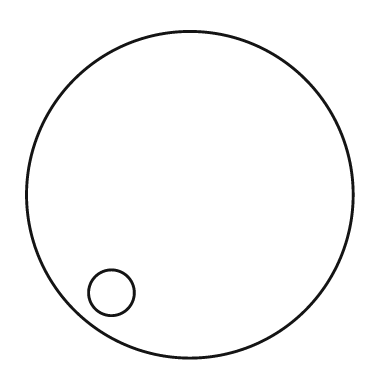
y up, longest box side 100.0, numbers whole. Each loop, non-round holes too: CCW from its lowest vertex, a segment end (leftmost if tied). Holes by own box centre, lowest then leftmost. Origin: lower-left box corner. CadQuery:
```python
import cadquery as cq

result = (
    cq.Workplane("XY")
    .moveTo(50.0, 50.0)
    .circle(50.0)
    .moveTo(26.0, 20.0)
    .circle(7.0)
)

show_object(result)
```